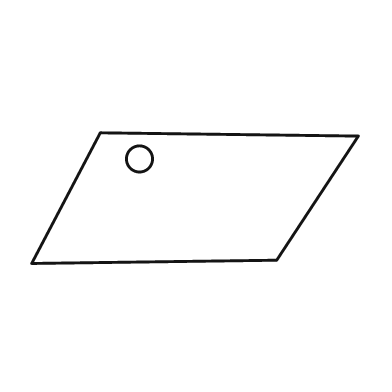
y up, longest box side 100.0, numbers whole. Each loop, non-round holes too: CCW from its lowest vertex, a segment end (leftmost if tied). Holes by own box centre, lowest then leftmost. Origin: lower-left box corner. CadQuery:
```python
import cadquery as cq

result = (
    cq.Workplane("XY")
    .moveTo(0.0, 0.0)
    .lineTo(75.0, 1.0)
    .lineTo(100.0, 39.0)
    .lineTo(21.0, 40.0)
    .close()
    .moveTo(33.0, 32.0)
    .circle(4.0)
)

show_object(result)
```